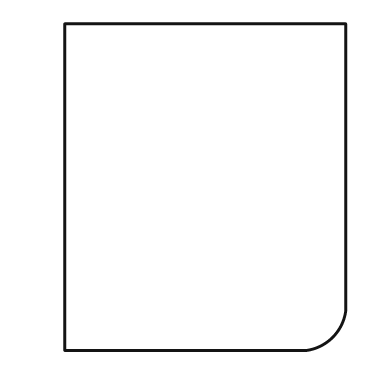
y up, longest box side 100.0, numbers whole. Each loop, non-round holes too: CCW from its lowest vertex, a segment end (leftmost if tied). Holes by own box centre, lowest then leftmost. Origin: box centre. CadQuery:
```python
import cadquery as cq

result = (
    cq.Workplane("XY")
    .moveTo(-43.0, -50.0)
    .lineTo(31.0, -50.0)
    .threePointArc((39.0, -46.0), (43.0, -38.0))
    .lineTo(43.0, 50.0)
    .lineTo(-43.0, 50.0)
    .close()
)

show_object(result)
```